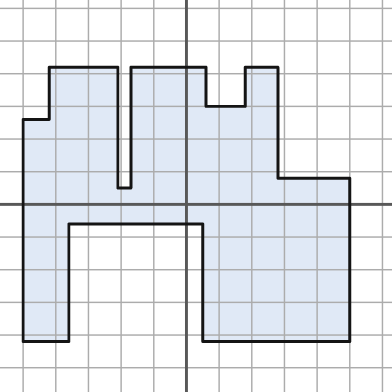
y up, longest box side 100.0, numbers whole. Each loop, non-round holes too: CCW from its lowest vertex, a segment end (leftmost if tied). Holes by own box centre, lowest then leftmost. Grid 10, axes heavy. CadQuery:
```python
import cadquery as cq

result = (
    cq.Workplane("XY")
    .moveTo(-50.0, -42.0)
    .lineTo(-36.0, -42.0)
    .lineTo(-36.0, -6.0)
    .lineTo(5.0, -6.0)
    .lineTo(5.0, -42.0)
    .lineTo(50.0, -42.0)
    .lineTo(50.0, 8.0)
    .lineTo(28.0, 8.0)
    .lineTo(28.0, 42.0)
    .lineTo(18.0, 42.0)
    .lineTo(18.0, 30.0)
    .lineTo(6.0, 30.0)
    .lineTo(6.0, 42.0)
    .lineTo(-17.0, 42.0)
    .lineTo(-17.0, 5.0)
    .lineTo(-21.0, 5.0)
    .lineTo(-21.0, 42.0)
    .lineTo(-42.0, 42.0)
    .lineTo(-42.0, 26.0)
    .lineTo(-50.0, 26.0)
    .close()
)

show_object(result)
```